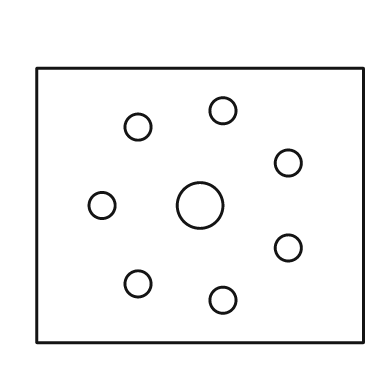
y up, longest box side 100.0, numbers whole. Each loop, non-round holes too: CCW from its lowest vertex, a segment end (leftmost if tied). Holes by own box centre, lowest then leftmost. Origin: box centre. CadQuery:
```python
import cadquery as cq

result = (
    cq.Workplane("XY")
    .moveTo(-50.0, -42.0)
    .lineTo(50.0, -42.0)
    .lineTo(50.0, 42.0)
    .lineTo(-50.0, 42.0)
    .close()
    .moveTo(7.0, -29.0)
    .circle(4.0)
    .moveTo(-19.0, -24.0)
    .circle(4.0)
    .moveTo(27.0, -13.0)
    .circle(4.0)
    .moveTo(-30.0, 0.0)
    .circle(4.0)
    .moveTo(0.0, 0.0)
    .circle(7.0)
    .moveTo(27.0, 13.0)
    .circle(4.0)
    .moveTo(-19.0, 24.0)
    .circle(4.0)
    .moveTo(7.0, 29.0)
    .circle(4.0)
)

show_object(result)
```